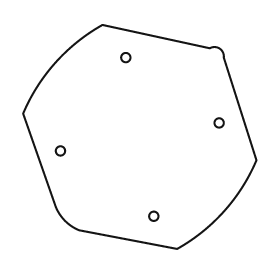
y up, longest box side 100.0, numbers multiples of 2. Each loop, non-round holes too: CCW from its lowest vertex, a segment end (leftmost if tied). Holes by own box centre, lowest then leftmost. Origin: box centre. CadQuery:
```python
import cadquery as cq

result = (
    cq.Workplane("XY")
    .moveTo(16.0, -48.0)
    .threePointArc((36.0, -32.0), (50.0, -10.0))
    .lineTo(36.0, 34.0)
    .threePointArc((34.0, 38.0), (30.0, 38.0))
    .lineTo(-16.0, 48.0)
    .threePointArc((-36.0, 32.0), (-50.0, 10.0))
    .lineTo(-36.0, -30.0)
    .threePointArc((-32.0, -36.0), (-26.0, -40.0))
    .close()
    .moveTo(6.0, -34.0)
    .circle(2.0)
    .moveTo(-34.0, -6.0)
    .circle(2.0)
    .moveTo(34.0, 6.0)
    .circle(2.0)
    .moveTo(-6.0, 34.0)
    .circle(2.0)
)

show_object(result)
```